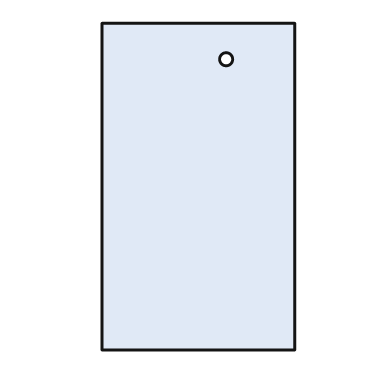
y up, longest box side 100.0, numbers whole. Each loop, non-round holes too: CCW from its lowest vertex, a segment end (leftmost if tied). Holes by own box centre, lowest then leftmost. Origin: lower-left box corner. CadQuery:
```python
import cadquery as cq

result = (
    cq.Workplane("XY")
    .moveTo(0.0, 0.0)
    .lineTo(59.0, 0.0)
    .lineTo(59.0, 100.0)
    .lineTo(0.0, 100.0)
    .close()
    .moveTo(38.0, 89.0)
    .circle(2.0)
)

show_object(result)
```